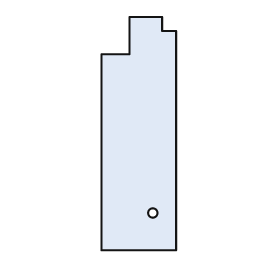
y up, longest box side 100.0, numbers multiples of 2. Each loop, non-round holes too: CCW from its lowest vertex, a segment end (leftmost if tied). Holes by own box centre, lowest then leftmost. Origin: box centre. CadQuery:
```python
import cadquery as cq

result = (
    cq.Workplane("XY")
    .moveTo(-16.0, -50.0)
    .lineTo(16.0, -50.0)
    .lineTo(16.0, 44.0)
    .lineTo(10.0, 44.0)
    .lineTo(10.0, 50.0)
    .lineTo(-4.0, 50.0)
    .lineTo(-4.0, 34.0)
    .lineTo(-16.0, 34.0)
    .close()
    .moveTo(6.0, -34.0)
    .circle(2.0)
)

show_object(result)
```